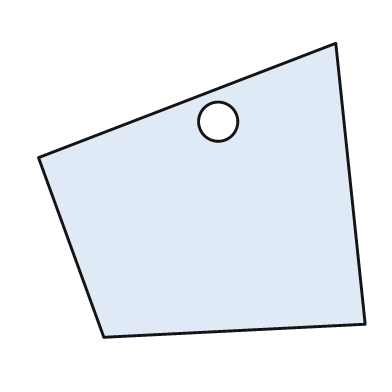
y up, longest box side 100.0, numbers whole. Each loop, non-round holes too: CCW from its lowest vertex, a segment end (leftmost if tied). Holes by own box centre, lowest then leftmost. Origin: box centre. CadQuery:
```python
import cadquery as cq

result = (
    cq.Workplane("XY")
    .moveTo(-30.0, -45.0)
    .lineTo(50.0, -41.0)
    .lineTo(41.0, 45.0)
    .lineTo(-50.0, 10.0)
    .close()
    .moveTo(5.0, 21.0)
    .circle(6.0)
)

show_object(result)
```